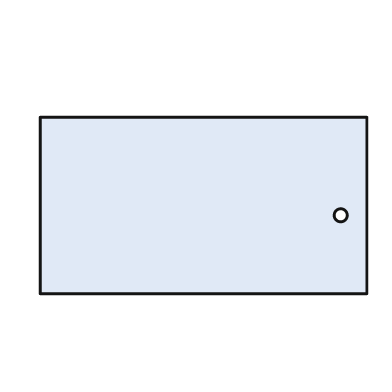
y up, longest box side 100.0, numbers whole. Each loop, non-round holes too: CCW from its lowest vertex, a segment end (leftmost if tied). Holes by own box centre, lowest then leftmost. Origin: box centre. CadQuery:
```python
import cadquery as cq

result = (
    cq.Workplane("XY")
    .moveTo(-50.0, -27.0)
    .lineTo(50.0, -27.0)
    .lineTo(50.0, 27.0)
    .lineTo(-50.0, 27.0)
    .close()
    .moveTo(42.0, -3.0)
    .circle(2.0)
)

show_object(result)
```